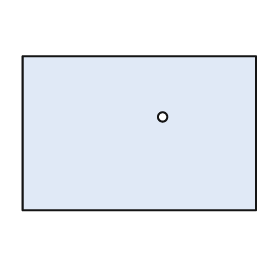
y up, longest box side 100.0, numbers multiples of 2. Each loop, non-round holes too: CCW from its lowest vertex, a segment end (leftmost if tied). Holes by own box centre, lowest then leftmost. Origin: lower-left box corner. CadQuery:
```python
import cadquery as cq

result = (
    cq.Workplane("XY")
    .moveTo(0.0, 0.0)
    .lineTo(100.0, 0.0)
    .lineTo(100.0, 66.0)
    .lineTo(0.0, 66.0)
    .close()
    .moveTo(60.0, 40.0)
    .circle(2.0)
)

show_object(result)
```